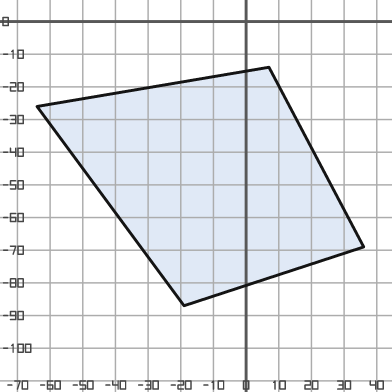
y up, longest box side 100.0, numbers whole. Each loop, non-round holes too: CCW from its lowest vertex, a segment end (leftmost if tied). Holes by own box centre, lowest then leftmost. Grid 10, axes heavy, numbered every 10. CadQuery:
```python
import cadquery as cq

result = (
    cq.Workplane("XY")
    .moveTo(-19.0, -87.0)
    .lineTo(36.0, -69.0)
    .lineTo(7.0, -14.0)
    .lineTo(-64.0, -26.0)
    .close()
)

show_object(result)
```